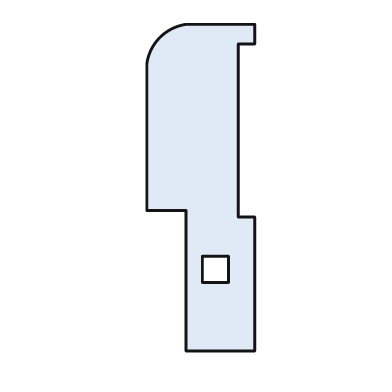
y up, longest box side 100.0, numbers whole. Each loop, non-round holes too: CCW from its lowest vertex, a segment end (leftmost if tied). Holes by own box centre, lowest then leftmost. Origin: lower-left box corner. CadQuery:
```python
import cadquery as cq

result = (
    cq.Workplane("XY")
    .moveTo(12.0, 0.0)
    .lineTo(33.0, 0.0)
    .lineTo(33.0, 41.0)
    .lineTo(28.0, 41.0)
    .lineTo(28.0, 94.0)
    .lineTo(33.0, 94.0)
    .lineTo(33.0, 100.0)
    .lineTo(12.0, 100.0)
    .threePointArc((4.0, 96.0), (0.0, 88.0))
    .lineTo(0.0, 43.0)
    .lineTo(12.0, 43.0)
    .close()
    .moveTo(17.0, 21.0)
    .lineTo(25.0, 21.0)
    .lineTo(25.0, 29.0)
    .lineTo(17.0, 29.0)
    .close()
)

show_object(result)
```